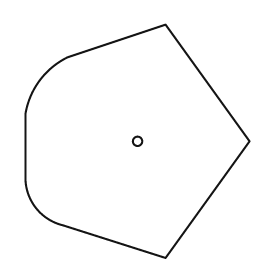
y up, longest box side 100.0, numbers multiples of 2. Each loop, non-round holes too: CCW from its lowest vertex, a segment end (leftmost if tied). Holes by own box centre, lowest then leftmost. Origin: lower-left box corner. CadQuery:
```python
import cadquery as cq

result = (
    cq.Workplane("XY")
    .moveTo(60.0, 0.0)
    .lineTo(96.0, 50.0)
    .lineTo(60.0, 100.0)
    .lineTo(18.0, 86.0)
    .threePointArc((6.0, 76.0), (0.0, 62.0))
    .lineTo(0.0, 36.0)
    .threePointArc((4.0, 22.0), (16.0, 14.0))
    .close()
    .moveTo(48.0, 50.0)
    .circle(2.0)
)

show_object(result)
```